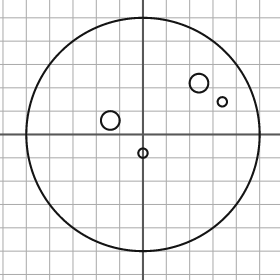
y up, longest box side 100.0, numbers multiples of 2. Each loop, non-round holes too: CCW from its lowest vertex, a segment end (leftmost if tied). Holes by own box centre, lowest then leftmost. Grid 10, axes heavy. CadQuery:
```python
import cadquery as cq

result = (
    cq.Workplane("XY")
    .moveTo(0.0, 0.0)
    .circle(50.0)
    .moveTo(0.0, -8.0)
    .circle(2.0)
    .moveTo(-14.0, 6.0)
    .circle(4.0)
    .moveTo(34.0, 14.0)
    .circle(2.0)
    .moveTo(24.0, 22.0)
    .circle(4.0)
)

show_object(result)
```